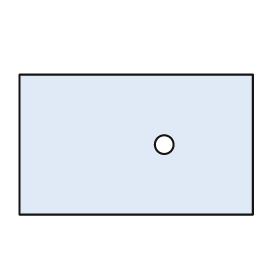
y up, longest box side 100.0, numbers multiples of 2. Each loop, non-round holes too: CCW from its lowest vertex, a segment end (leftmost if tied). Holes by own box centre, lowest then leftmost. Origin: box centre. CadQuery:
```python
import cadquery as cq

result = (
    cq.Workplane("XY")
    .moveTo(-50.0, -30.0)
    .lineTo(50.0, -30.0)
    .lineTo(50.0, 30.0)
    .lineTo(-50.0, 30.0)
    .close()
    .moveTo(12.0, 0.0)
    .circle(4.0)
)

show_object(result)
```